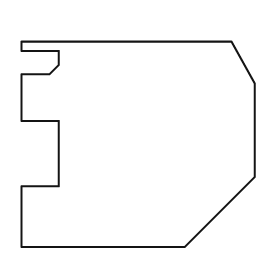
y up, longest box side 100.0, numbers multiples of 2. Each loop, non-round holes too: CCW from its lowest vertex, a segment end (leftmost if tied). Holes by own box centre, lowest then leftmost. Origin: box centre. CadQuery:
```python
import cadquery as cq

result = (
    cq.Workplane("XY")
    .moveTo(-50.0, -44.0)
    .lineTo(20.0, -44.0)
    .lineTo(50.0, -14.0)
    .lineTo(50.0, 26.0)
    .lineTo(40.0, 44.0)
    .lineTo(-50.0, 44.0)
    .lineTo(-50.0, 40.0)
    .lineTo(-34.0, 40.0)
    .lineTo(-34.0, 34.0)
    .lineTo(-38.0, 30.0)
    .lineTo(-50.0, 30.0)
    .lineTo(-50.0, 10.0)
    .lineTo(-34.0, 10.0)
    .lineTo(-34.0, -18.0)
    .lineTo(-50.0, -18.0)
    .close()
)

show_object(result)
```